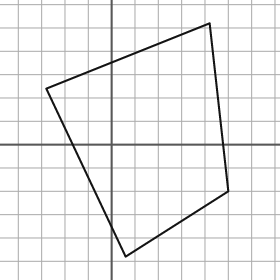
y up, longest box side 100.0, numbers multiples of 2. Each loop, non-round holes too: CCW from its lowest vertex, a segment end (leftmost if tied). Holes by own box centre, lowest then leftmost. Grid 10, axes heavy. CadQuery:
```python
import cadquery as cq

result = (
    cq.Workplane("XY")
    .moveTo(6.0, -48.0)
    .lineTo(50.0, -20.0)
    .lineTo(42.0, 52.0)
    .lineTo(-28.0, 24.0)
    .close()
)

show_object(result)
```